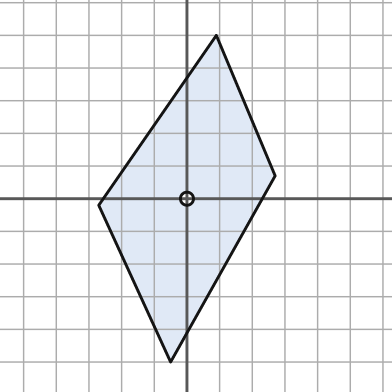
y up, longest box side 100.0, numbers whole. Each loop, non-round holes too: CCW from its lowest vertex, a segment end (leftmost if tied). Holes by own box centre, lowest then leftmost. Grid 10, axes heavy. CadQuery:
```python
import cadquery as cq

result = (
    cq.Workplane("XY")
    .moveTo(-5.0, -50.0)
    .lineTo(27.0, 7.0)
    .lineTo(9.0, 50.0)
    .lineTo(-27.0, -2.0)
    .close()
    .moveTo(0.0, 0.0)
    .circle(2.0)
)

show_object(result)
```